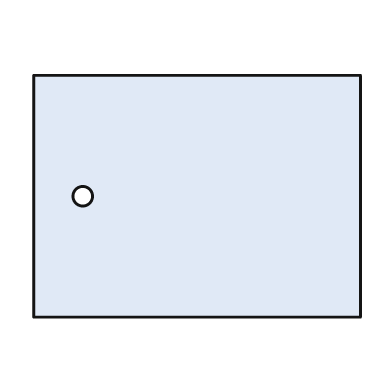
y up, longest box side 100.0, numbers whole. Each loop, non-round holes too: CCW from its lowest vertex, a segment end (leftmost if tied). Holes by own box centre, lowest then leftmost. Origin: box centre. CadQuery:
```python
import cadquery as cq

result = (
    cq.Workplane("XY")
    .moveTo(-50.0, -37.0)
    .lineTo(50.0, -37.0)
    .lineTo(50.0, 37.0)
    .lineTo(-50.0, 37.0)
    .close()
    .moveTo(-35.0, 0.0)
    .circle(3.0)
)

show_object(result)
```